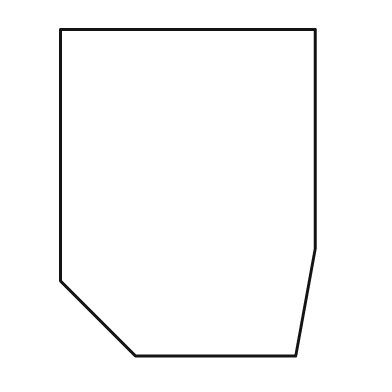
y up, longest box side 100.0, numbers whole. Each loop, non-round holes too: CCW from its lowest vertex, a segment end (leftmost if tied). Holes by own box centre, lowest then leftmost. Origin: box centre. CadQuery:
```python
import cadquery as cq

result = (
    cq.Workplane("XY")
    .moveTo(-16.0, -50.0)
    .lineTo(33.0, -50.0)
    .lineTo(39.0, -17.0)
    .lineTo(39.0, 50.0)
    .lineTo(-39.0, 50.0)
    .lineTo(-39.0, -27.0)
    .close()
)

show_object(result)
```